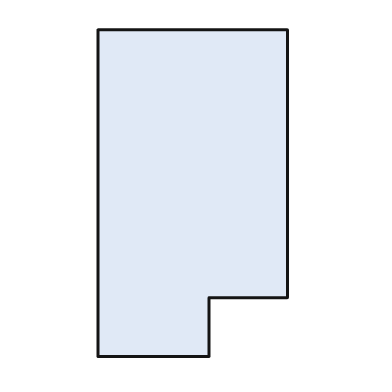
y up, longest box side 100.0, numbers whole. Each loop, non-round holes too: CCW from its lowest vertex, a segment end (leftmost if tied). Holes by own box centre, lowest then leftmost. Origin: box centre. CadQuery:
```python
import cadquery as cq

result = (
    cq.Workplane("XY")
    .moveTo(-29.0, -50.0)
    .lineTo(5.0, -50.0)
    .lineTo(5.0, -32.0)
    .lineTo(29.0, -32.0)
    .lineTo(29.0, 50.0)
    .lineTo(-29.0, 50.0)
    .close()
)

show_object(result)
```